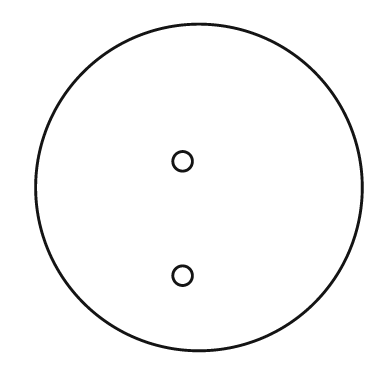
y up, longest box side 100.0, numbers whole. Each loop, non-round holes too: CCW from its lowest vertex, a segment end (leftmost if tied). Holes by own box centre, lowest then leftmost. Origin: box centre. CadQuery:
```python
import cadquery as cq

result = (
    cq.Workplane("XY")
    .moveTo(0.0, 0.0)
    .circle(50.0)
    .moveTo(-5.0, -27.0)
    .circle(3.0)
    .moveTo(-5.0, 8.0)
    .circle(3.0)
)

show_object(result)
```